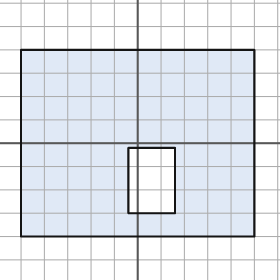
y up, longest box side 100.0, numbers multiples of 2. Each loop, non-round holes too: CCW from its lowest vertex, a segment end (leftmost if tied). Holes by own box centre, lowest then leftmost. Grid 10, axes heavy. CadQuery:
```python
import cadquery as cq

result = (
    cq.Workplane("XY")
    .moveTo(-50.0, -40.0)
    .lineTo(50.0, -40.0)
    .lineTo(50.0, 40.0)
    .lineTo(-50.0, 40.0)
    .close()
    .moveTo(-4.0, -30.0)
    .lineTo(16.0, -30.0)
    .lineTo(16.0, -2.0)
    .lineTo(-4.0, -2.0)
    .close()
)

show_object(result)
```